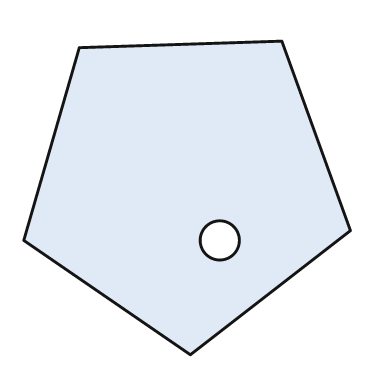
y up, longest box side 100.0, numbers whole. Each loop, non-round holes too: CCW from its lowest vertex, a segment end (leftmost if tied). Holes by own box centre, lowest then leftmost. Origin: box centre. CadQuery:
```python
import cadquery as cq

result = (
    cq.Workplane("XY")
    .moveTo(1.0, -48.0)
    .lineTo(50.0, -10.0)
    .lineTo(29.0, 48.0)
    .lineTo(-33.0, 46.0)
    .lineTo(-50.0, -13.0)
    .close()
    .moveTo(10.0, -13.0)
    .circle(6.0)
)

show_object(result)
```